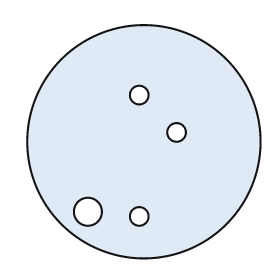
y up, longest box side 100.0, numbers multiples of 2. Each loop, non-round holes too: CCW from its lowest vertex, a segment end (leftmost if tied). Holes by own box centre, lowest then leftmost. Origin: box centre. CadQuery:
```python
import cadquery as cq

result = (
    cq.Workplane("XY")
    .moveTo(0.0, 0.0)
    .circle(50.0)
    .moveTo(-2.0, -32.0)
    .circle(4.0)
    .moveTo(-24.0, -30.0)
    .circle(6.0)
    .moveTo(14.0, 4.0)
    .circle(4.0)
    .moveTo(-2.0, 20.0)
    .circle(4.0)
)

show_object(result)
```